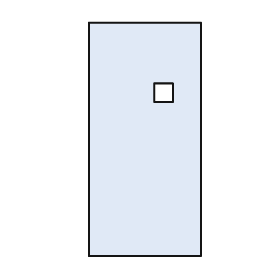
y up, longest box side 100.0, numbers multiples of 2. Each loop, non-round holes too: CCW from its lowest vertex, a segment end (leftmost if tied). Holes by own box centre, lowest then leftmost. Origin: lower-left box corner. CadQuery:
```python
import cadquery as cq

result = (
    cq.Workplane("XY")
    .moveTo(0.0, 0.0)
    .lineTo(48.0, 0.0)
    .lineTo(48.0, 100.0)
    .lineTo(0.0, 100.0)
    .close()
    .moveTo(28.0, 66.0)
    .lineTo(36.0, 66.0)
    .lineTo(36.0, 74.0)
    .lineTo(28.0, 74.0)
    .close()
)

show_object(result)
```